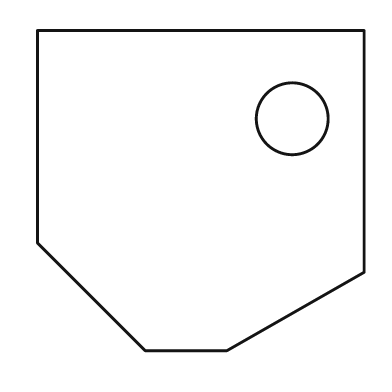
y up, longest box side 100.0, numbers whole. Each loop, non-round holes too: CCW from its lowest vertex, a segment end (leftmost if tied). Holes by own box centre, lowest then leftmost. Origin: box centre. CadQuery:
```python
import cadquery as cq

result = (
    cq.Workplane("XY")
    .moveTo(-17.0, -49.0)
    .lineTo(8.0, -49.0)
    .lineTo(50.0, -25.0)
    .lineTo(50.0, 49.0)
    .lineTo(-50.0, 49.0)
    .lineTo(-50.0, -16.0)
    .close()
    .moveTo(28.0, 22.0)
    .circle(11.0)
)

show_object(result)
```